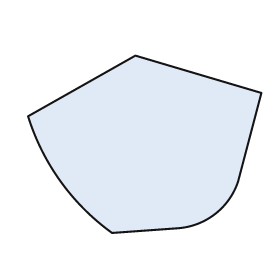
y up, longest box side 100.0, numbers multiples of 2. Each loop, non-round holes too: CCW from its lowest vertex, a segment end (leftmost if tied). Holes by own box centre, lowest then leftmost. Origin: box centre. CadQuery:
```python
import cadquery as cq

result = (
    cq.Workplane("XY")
    .moveTo(-14.0, -38.0)
    .lineTo(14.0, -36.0)
    .threePointArc((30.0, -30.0), (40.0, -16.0))
    .lineTo(50.0, 22.0)
    .lineTo(-4.0, 38.0)
    .lineTo(-50.0, 12.0)
    .threePointArc((-36.0, -16.0), (-14.0, -38.0))
    .close()
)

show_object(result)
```